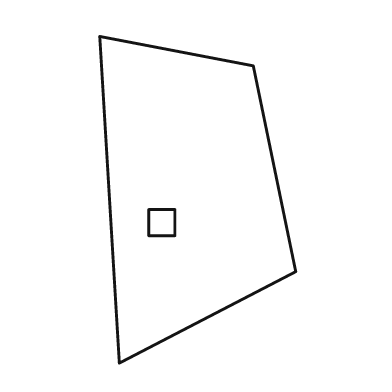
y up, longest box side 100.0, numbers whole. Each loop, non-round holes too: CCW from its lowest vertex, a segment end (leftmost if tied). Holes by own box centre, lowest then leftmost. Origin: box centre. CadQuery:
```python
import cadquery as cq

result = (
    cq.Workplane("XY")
    .moveTo(-24.0, -50.0)
    .lineTo(30.0, -22.0)
    .lineTo(17.0, 41.0)
    .lineTo(-30.0, 50.0)
    .close()
    .moveTo(-15.0, -11.0)
    .lineTo(-7.0, -11.0)
    .lineTo(-7.0, -3.0)
    .lineTo(-15.0, -3.0)
    .close()
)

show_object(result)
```